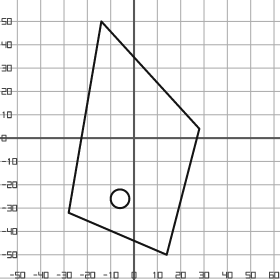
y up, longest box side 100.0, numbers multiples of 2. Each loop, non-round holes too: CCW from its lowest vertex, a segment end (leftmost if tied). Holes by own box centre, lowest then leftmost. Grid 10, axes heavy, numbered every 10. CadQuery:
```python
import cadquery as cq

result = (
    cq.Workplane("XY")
    .moveTo(14.0, -50.0)
    .lineTo(28.0, 4.0)
    .lineTo(-14.0, 50.0)
    .lineTo(-28.0, -32.0)
    .close()
    .moveTo(-6.0, -26.0)
    .circle(4.0)
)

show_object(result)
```